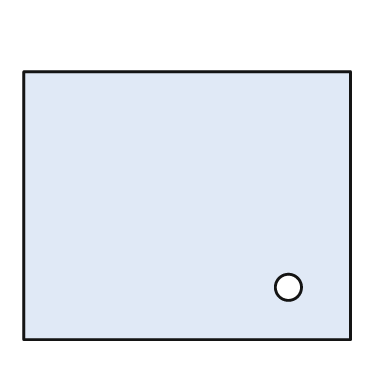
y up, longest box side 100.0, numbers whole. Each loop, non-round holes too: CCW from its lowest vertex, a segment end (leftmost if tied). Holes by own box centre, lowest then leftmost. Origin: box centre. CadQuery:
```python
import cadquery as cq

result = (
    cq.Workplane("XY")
    .moveTo(-50.0, -41.0)
    .lineTo(50.0, -41.0)
    .lineTo(50.0, 41.0)
    .lineTo(-50.0, 41.0)
    .close()
    .moveTo(31.0, -25.0)
    .circle(4.0)
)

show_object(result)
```